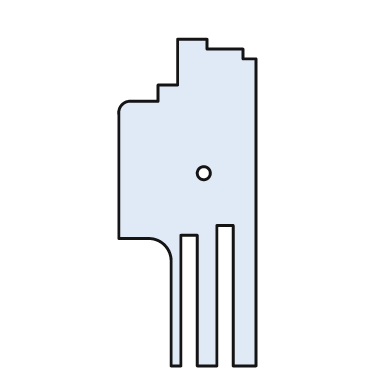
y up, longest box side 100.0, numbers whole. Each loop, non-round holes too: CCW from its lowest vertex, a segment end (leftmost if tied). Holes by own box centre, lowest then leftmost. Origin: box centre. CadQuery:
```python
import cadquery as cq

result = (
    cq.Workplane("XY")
    .moveTo(-5.0, -50.0)
    .lineTo(-2.0, -50.0)
    .lineTo(-2.0, -10.0)
    .lineTo(3.0, -10.0)
    .lineTo(3.0, -50.0)
    .lineTo(9.0, -50.0)
    .lineTo(9.0, -7.0)
    .lineTo(14.0, -7.0)
    .lineTo(14.0, -50.0)
    .lineTo(21.0, -50.0)
    .lineTo(21.0, 44.0)
    .lineTo(17.0, 44.0)
    .lineTo(17.0, 47.0)
    .lineTo(6.0, 47.0)
    .lineTo(6.0, 50.0)
    .lineTo(-3.0, 50.0)
    .lineTo(-3.0, 36.0)
    .lineTo(-9.0, 36.0)
    .lineTo(-9.0, 31.0)
    .lineTo(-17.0, 31.0)
    .threePointArc((-20.0, 30.0), (-21.0, 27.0))
    .lineTo(-21.0, -11.0)
    .lineTo(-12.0, -11.0)
    .threePointArc((-7.0, -13.0), (-5.0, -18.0))
    .close()
    .moveTo(5.0, 9.0)
    .circle(2.0)
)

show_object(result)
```